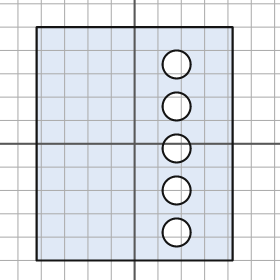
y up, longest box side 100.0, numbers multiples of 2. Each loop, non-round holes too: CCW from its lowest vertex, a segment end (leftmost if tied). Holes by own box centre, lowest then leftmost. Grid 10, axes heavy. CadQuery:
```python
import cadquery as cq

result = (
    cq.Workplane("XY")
    .moveTo(-42.0, -50.0)
    .lineTo(42.0, -50.0)
    .lineTo(42.0, 50.0)
    .lineTo(-42.0, 50.0)
    .close()
    .moveTo(18.0, -38.0)
    .circle(6.0)
    .moveTo(18.0, -20.0)
    .circle(6.0)
    .moveTo(18.0, -2.0)
    .circle(6.0)
    .moveTo(18.0, 16.0)
    .circle(6.0)
    .moveTo(18.0, 34.0)
    .circle(6.0)
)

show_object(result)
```